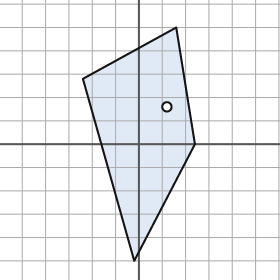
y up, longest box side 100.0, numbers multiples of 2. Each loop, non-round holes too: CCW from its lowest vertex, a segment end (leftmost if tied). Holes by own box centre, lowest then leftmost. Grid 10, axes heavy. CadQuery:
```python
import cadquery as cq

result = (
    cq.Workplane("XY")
    .moveTo(-2.0, -50.0)
    .lineTo(24.0, 0.0)
    .lineTo(16.0, 50.0)
    .lineTo(-24.0, 28.0)
    .close()
    .moveTo(12.0, 16.0)
    .circle(2.0)
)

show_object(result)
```